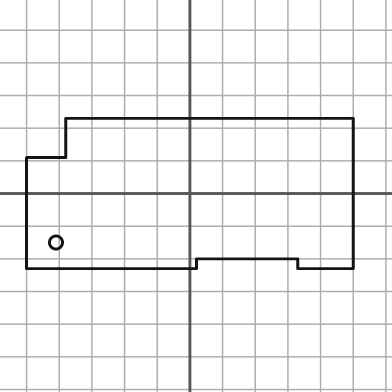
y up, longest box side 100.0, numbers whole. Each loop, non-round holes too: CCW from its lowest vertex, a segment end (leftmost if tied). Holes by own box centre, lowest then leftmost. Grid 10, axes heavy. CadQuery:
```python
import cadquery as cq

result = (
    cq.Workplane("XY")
    .moveTo(-50.0, -23.0)
    .lineTo(2.0, -23.0)
    .lineTo(2.0, -20.0)
    .lineTo(33.0, -20.0)
    .lineTo(33.0, -23.0)
    .lineTo(50.0, -23.0)
    .lineTo(50.0, 23.0)
    .lineTo(-38.0, 23.0)
    .lineTo(-38.0, 11.0)
    .lineTo(-50.0, 11.0)
    .close()
    .moveTo(-41.0, -15.0)
    .circle(2.0)
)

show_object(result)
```